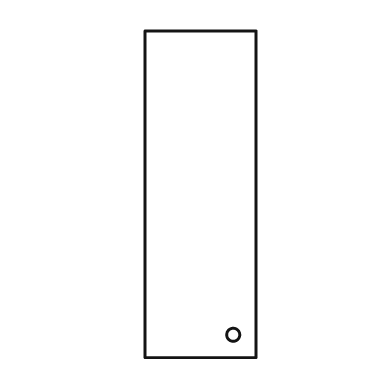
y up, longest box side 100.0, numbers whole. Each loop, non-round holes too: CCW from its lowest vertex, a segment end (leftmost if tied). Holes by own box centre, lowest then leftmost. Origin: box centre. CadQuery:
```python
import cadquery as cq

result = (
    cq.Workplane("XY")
    .moveTo(-17.0, -50.0)
    .lineTo(17.0, -50.0)
    .lineTo(17.0, 50.0)
    .lineTo(-17.0, 50.0)
    .close()
    .moveTo(10.0, -43.0)
    .circle(2.0)
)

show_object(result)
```